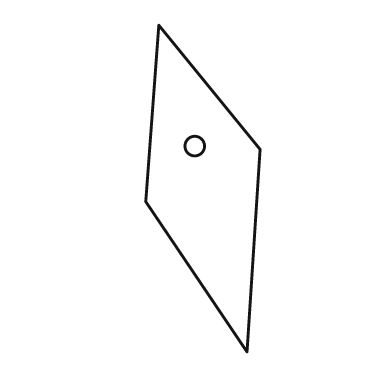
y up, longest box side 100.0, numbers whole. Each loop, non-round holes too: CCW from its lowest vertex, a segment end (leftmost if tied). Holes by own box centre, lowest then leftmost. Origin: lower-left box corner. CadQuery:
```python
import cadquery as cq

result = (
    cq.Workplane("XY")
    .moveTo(31.0, 0.0)
    .lineTo(35.0, 62.0)
    .lineTo(4.0, 100.0)
    .lineTo(0.0, 46.0)
    .close()
    .moveTo(15.0, 63.0)
    .circle(3.0)
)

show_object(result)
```